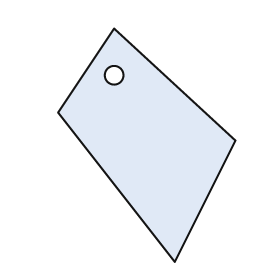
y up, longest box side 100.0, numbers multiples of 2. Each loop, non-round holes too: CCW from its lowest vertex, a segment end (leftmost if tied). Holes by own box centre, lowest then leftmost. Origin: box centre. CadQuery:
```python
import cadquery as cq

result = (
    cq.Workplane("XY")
    .moveTo(12.0, -50.0)
    .lineTo(38.0, 2.0)
    .lineTo(-14.0, 50.0)
    .lineTo(-38.0, 14.0)
    .close()
    .moveTo(-14.0, 30.0)
    .circle(4.0)
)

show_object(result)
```